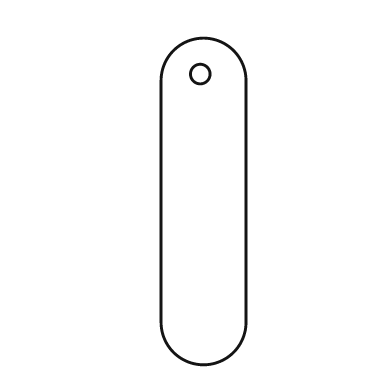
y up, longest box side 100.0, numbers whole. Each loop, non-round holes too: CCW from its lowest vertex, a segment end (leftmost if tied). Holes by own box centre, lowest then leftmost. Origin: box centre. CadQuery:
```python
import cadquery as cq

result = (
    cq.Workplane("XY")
    .moveTo(-13.0, -37.0)
    .threePointArc((0.0, -50.0), (13.0, -37.0))
    .lineTo(13.0, 37.0)
    .threePointArc((0.0, 50.0), (-13.0, 37.0))
    .close()
    .moveTo(-1.0, 39.0)
    .circle(3.0)
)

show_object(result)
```